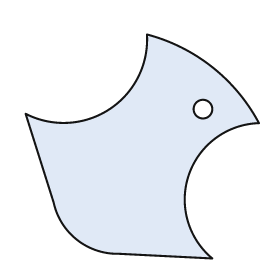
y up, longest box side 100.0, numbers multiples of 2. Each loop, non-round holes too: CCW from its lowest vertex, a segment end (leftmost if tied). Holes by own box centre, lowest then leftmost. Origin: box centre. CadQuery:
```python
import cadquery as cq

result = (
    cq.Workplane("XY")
    .moveTo(30.0, -48.0)
    .threePointArc((20.0, -12.0), (50.0, 10.0))
    .threePointArc((30.0, 34.0), (2.0, 48.0))
    .threePointArc((-14.0, 16.0), (-50.0, 14.0))
    .lineTo(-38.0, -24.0)
    .threePointArc((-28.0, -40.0), (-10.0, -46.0))
    .close()
    .moveTo(26.0, 16.0)
    .circle(4.0)
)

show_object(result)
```